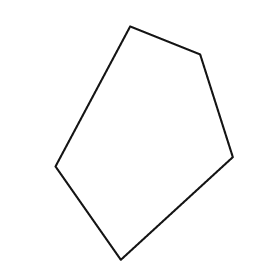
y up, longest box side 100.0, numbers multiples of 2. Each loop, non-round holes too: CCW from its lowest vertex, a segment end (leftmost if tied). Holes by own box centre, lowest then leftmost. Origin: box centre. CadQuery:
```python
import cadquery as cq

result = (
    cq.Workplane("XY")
    .moveTo(-10.0, -50.0)
    .lineTo(38.0, -6.0)
    .lineTo(24.0, 38.0)
    .lineTo(-6.0, 50.0)
    .lineTo(-38.0, -10.0)
    .close()
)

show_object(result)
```